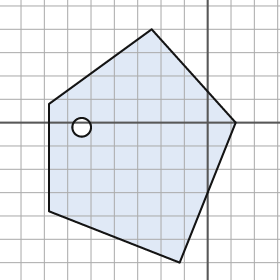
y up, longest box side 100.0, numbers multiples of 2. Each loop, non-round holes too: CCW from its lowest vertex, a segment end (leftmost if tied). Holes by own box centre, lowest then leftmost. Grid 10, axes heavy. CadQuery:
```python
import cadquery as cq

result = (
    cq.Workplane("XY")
    .moveTo(-12.0, -60.0)
    .lineTo(12.0, 0.0)
    .lineTo(-24.0, 40.0)
    .lineTo(-68.0, 8.0)
    .lineTo(-68.0, -38.0)
    .close()
    .moveTo(-54.0, -2.0)
    .circle(4.0)
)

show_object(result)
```